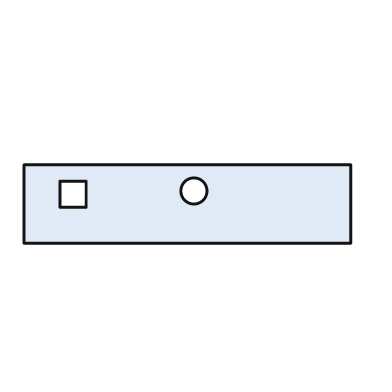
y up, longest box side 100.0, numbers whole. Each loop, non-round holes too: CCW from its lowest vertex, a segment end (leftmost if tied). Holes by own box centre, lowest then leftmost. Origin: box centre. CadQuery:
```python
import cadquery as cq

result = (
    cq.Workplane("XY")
    .moveTo(-50.0, -12.0)
    .lineTo(50.0, -12.0)
    .lineTo(50.0, 12.0)
    .lineTo(-50.0, 12.0)
    .close()
    .moveTo(-39.0, -1.0)
    .lineTo(-31.0, -1.0)
    .lineTo(-31.0, 7.0)
    .lineTo(-39.0, 7.0)
    .close()
    .moveTo(2.0, 4.0)
    .circle(4.0)
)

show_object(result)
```